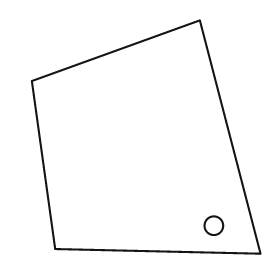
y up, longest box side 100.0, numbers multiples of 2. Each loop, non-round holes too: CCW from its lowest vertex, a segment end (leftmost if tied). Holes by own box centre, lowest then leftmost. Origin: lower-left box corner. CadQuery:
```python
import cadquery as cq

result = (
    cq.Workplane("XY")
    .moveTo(98.0, 0.0)
    .lineTo(72.0, 100.0)
    .lineTo(0.0, 74.0)
    .lineTo(10.0, 2.0)
    .close()
    .moveTo(78.0, 12.0)
    .circle(4.0)
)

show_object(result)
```